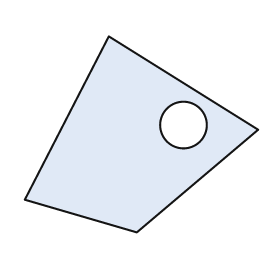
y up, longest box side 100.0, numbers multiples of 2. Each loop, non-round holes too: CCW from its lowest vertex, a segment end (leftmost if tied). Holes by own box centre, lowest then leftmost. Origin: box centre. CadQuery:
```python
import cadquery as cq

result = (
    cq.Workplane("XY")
    .moveTo(-2.0, -42.0)
    .lineTo(50.0, 2.0)
    .lineTo(-14.0, 42.0)
    .lineTo(-50.0, -28.0)
    .close()
    .moveTo(18.0, 4.0)
    .circle(10.0)
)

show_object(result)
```